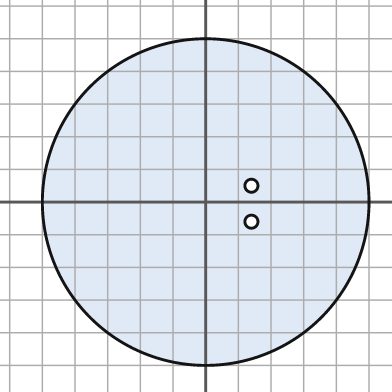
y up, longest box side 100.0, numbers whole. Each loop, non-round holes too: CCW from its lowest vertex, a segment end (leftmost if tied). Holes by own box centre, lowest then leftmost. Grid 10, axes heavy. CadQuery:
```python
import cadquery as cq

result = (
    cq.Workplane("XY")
    .moveTo(0.0, 0.0)
    .circle(50.0)
    .moveTo(14.0, -6.0)
    .circle(2.0)
    .moveTo(14.0, 5.0)
    .circle(2.0)
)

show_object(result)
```